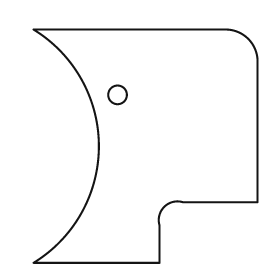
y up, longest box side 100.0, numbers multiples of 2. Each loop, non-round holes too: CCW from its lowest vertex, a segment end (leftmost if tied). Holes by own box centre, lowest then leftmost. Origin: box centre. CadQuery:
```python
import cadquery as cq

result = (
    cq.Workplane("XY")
    .moveTo(-48.0, -50.0)
    .lineTo(6.0, -50.0)
    .lineTo(6.0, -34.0)
    .threePointArc((8.0, -26.0), (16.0, -24.0))
    .lineTo(48.0, -24.0)
    .lineTo(48.0, 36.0)
    .threePointArc((44.0, 46.0), (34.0, 50.0))
    .lineTo(-48.0, 50.0)
    .threePointArc((-20.0, 0.0), (-48.0, -50.0))
    .close()
    .moveTo(-12.0, 22.0)
    .circle(4.0)
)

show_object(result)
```